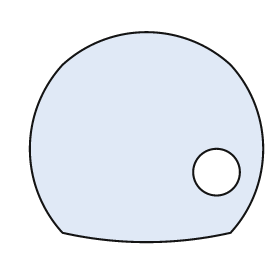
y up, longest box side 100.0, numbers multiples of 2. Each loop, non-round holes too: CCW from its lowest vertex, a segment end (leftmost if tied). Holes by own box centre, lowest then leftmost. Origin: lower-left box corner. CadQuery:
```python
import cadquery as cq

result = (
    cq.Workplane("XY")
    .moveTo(14.0, 4.0)
    .threePointArc((50.0, 0.0), (86.0, 4.0))
    .threePointArc((100.0, 40.0), (86.0, 76.0))
    .threePointArc((50.0, 90.0), (14.0, 76.0))
    .threePointArc((0.0, 40.0), (14.0, 4.0))
    .close()
    .moveTo(80.0, 30.0)
    .circle(10.0)
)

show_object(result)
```